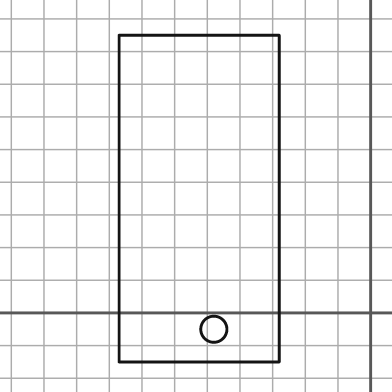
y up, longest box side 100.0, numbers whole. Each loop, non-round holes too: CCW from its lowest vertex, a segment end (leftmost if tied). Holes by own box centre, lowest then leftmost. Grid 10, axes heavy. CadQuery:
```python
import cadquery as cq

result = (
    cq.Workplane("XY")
    .moveTo(-77.0, -15.0)
    .lineTo(-28.0, -15.0)
    .lineTo(-28.0, 85.0)
    .lineTo(-77.0, 85.0)
    .close()
    .moveTo(-48.0, -5.0)
    .circle(4.0)
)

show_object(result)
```